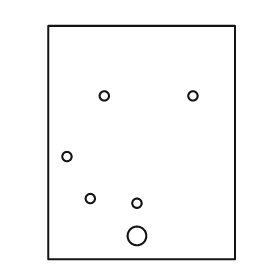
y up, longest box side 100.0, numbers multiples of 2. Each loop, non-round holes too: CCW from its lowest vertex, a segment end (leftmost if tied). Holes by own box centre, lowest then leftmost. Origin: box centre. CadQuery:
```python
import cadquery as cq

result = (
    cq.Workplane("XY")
    .moveTo(-40.0, -50.0)
    .lineTo(40.0, -50.0)
    .lineTo(40.0, 50.0)
    .lineTo(-40.0, 50.0)
    .close()
    .moveTo(-2.0, -40.0)
    .circle(4.0)
    .moveTo(-2.0, -26.0)
    .circle(2.0)
    .moveTo(-22.0, -24.0)
    .circle(2.0)
    .moveTo(-32.0, -6.0)
    .circle(2.0)
    .moveTo(-16.0, 20.0)
    .circle(2.0)
    .moveTo(22.0, 20.0)
    .circle(2.0)
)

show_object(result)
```